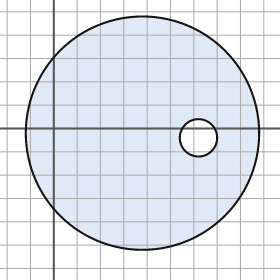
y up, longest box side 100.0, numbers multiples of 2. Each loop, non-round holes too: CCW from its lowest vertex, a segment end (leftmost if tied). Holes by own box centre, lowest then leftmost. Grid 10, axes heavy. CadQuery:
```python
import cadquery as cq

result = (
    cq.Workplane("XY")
    .moveTo(38.0, -2.0)
    .circle(50.0)
    .moveTo(62.0, -4.0)
    .circle(8.0)
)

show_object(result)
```